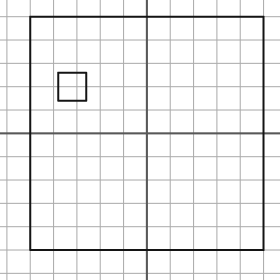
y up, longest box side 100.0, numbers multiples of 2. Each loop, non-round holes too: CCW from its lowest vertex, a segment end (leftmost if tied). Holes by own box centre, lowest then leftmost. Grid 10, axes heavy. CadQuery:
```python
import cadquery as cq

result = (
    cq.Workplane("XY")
    .moveTo(-50.0, -50.0)
    .lineTo(50.0, -50.0)
    .lineTo(50.0, 50.0)
    .lineTo(-50.0, 50.0)
    .close()
    .moveTo(-38.0, 14.0)
    .lineTo(-26.0, 14.0)
    .lineTo(-26.0, 26.0)
    .lineTo(-38.0, 26.0)
    .close()
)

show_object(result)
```